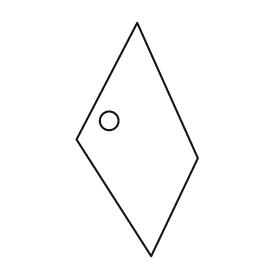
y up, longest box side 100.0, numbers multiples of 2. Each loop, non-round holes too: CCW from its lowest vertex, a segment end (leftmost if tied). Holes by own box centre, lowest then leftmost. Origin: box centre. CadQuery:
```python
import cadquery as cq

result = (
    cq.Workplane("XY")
    .moveTo(6.0, -50.0)
    .lineTo(26.0, -8.0)
    .lineTo(0.0, 50.0)
    .lineTo(-26.0, 0.0)
    .close()
    .moveTo(-12.0, 8.0)
    .circle(4.0)
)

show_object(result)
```